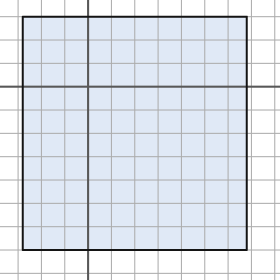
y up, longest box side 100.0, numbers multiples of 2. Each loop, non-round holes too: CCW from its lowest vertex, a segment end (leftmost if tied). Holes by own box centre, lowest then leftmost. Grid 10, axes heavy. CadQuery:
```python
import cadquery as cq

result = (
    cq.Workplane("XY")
    .moveTo(-28.0, -70.0)
    .lineTo(68.0, -70.0)
    .lineTo(68.0, 30.0)
    .lineTo(-28.0, 30.0)
    .close()
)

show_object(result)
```